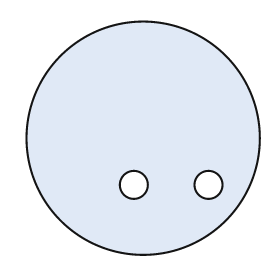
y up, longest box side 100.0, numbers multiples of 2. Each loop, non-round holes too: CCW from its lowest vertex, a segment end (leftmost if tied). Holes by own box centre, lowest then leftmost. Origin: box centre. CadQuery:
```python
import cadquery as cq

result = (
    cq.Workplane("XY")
    .moveTo(0.0, 0.0)
    .circle(50.0)
    .moveTo(-4.0, -20.0)
    .circle(6.0)
    .moveTo(28.0, -20.0)
    .circle(6.0)
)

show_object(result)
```